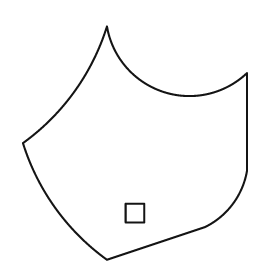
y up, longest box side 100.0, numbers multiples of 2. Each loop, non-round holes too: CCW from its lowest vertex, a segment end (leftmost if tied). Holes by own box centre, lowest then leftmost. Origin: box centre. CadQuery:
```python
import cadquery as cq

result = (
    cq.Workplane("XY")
    .moveTo(-12.0, -50.0)
    .lineTo(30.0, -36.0)
    .threePointArc((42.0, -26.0), (48.0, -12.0))
    .lineTo(48.0, 30.0)
    .threePointArc((12.0, 22.0), (-12.0, 50.0))
    .threePointArc((-26.0, 22.0), (-48.0, 0.0))
    .threePointArc((-34.0, -28.0), (-12.0, -50.0))
    .close()
    .moveTo(-4.0, -34.0)
    .lineTo(4.0, -34.0)
    .lineTo(4.0, -26.0)
    .lineTo(-4.0, -26.0)
    .close()
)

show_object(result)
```